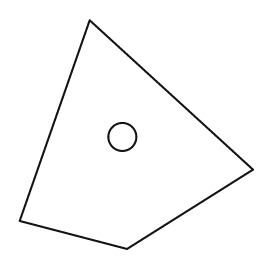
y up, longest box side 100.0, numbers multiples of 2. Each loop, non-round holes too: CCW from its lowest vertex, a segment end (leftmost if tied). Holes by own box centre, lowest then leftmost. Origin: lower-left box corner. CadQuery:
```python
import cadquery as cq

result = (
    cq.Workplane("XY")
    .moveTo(46.0, 0.0)
    .lineTo(100.0, 34.0)
    .lineTo(30.0, 98.0)
    .lineTo(0.0, 12.0)
    .close()
    .moveTo(44.0, 48.0)
    .circle(6.0)
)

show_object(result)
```